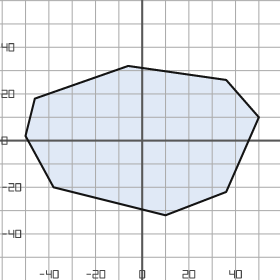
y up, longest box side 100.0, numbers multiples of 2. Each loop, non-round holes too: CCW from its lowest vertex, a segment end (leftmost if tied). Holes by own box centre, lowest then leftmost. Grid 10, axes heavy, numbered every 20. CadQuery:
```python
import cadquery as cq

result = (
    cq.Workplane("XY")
    .moveTo(10.0, -32.0)
    .lineTo(36.0, -22.0)
    .lineTo(50.0, 10.0)
    .lineTo(36.0, 26.0)
    .lineTo(-6.0, 32.0)
    .lineTo(-46.0, 18.0)
    .lineTo(-50.0, 2.0)
    .lineTo(-38.0, -20.0)
    .close()
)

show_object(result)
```